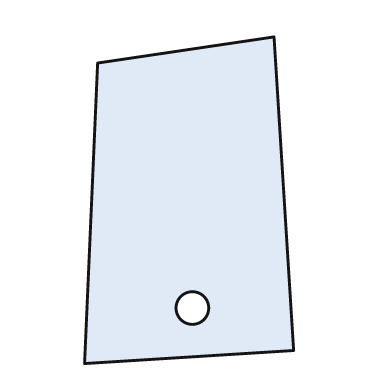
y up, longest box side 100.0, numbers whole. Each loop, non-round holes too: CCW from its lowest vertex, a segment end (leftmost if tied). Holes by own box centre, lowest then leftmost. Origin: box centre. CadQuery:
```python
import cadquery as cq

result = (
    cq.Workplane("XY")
    .moveTo(-32.0, -50.0)
    .lineTo(32.0, -46.0)
    .lineTo(26.0, 50.0)
    .lineTo(-28.0, 42.0)
    .close()
    .moveTo(1.0, -33.0)
    .circle(5.0)
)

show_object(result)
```